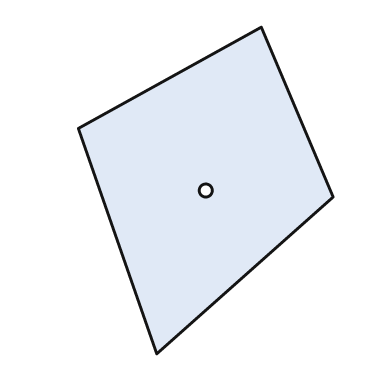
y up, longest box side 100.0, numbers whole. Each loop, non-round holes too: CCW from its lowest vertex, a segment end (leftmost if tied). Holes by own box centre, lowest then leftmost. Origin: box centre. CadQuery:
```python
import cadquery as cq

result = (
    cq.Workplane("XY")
    .moveTo(-15.0, -50.0)
    .lineTo(39.0, -2.0)
    .lineTo(17.0, 50.0)
    .lineTo(-39.0, 19.0)
    .close()
    .moveTo(0.0, 0.0)
    .circle(2.0)
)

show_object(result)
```